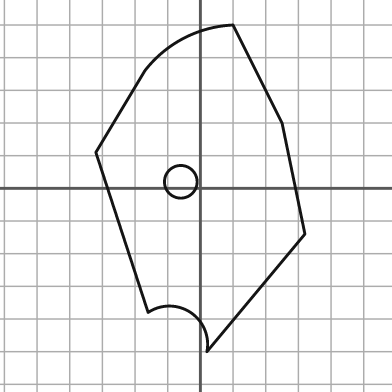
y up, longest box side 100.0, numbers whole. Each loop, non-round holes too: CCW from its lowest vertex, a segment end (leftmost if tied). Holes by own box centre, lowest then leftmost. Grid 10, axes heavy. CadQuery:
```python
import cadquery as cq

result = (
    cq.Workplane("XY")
    .moveTo(2.0, -50.0)
    .lineTo(32.0, -14.0)
    .lineTo(25.0, 20.0)
    .lineTo(10.0, 50.0)
    .threePointArc((-5.0, 46.0), (-17.0, 36.0))
    .lineTo(-32.0, 11.0)
    .lineTo(-16.0, -38.0)
    .threePointArc((-3.0, -38.0), (2.0, -50.0))
    .close()
    .moveTo(-6.0, 2.0)
    .circle(5.0)
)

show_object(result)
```